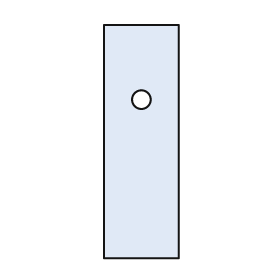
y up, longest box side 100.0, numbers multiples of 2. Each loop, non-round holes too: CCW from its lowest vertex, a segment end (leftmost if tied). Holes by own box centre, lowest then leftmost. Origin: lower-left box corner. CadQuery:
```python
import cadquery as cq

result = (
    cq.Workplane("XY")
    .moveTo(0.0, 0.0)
    .lineTo(32.0, 0.0)
    .lineTo(32.0, 100.0)
    .lineTo(0.0, 100.0)
    .close()
    .moveTo(16.0, 68.0)
    .circle(4.0)
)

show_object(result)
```